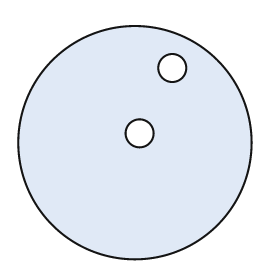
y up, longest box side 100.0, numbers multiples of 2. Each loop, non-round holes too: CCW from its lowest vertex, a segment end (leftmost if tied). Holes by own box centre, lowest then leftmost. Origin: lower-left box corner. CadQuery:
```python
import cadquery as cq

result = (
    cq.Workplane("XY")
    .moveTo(50.0, 50.0)
    .circle(50.0)
    .moveTo(52.0, 54.0)
    .circle(6.0)
    .moveTo(66.0, 82.0)
    .circle(6.0)
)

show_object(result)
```